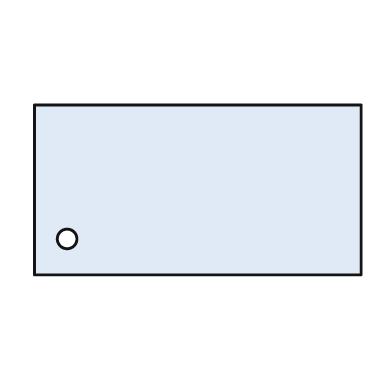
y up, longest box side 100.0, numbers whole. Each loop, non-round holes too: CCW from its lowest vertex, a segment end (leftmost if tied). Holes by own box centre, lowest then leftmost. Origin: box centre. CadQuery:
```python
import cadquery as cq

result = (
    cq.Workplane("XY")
    .moveTo(-50.0, -26.0)
    .lineTo(50.0, -26.0)
    .lineTo(50.0, 26.0)
    .lineTo(-50.0, 26.0)
    .close()
    .moveTo(-40.0, -15.0)
    .circle(3.0)
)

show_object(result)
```